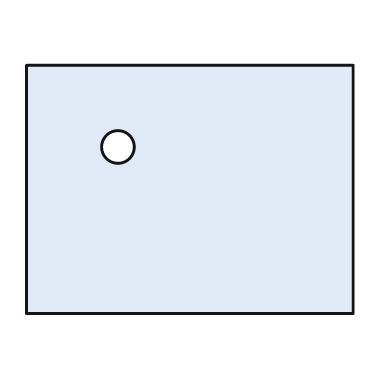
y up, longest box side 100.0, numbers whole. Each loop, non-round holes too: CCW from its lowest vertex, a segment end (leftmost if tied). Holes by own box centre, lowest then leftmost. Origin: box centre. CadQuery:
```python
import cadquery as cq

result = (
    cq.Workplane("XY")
    .moveTo(-50.0, -38.0)
    .lineTo(50.0, -38.0)
    .lineTo(50.0, 38.0)
    .lineTo(-50.0, 38.0)
    .close()
    .moveTo(-22.0, 13.0)
    .circle(5.0)
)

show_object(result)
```